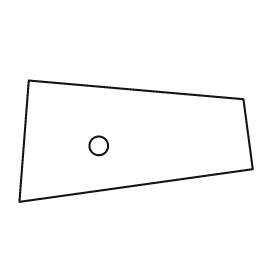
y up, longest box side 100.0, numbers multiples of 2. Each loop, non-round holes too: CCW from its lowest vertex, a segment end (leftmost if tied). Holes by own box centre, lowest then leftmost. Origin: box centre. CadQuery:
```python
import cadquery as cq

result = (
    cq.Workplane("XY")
    .moveTo(-50.0, -26.0)
    .lineTo(50.0, -12.0)
    .lineTo(46.0, 18.0)
    .lineTo(-46.0, 26.0)
    .close()
    .moveTo(-16.0, -2.0)
    .circle(4.0)
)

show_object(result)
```